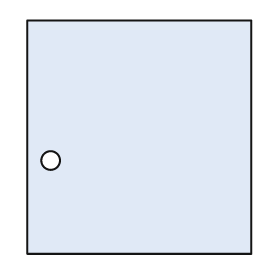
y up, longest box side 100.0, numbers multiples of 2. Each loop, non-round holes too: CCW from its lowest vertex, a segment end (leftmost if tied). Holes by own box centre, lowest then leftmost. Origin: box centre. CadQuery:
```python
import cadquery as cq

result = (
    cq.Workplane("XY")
    .moveTo(-48.0, -50.0)
    .lineTo(48.0, -50.0)
    .lineTo(48.0, 50.0)
    .lineTo(-48.0, 50.0)
    .close()
    .moveTo(-38.0, -10.0)
    .circle(4.0)
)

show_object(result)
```